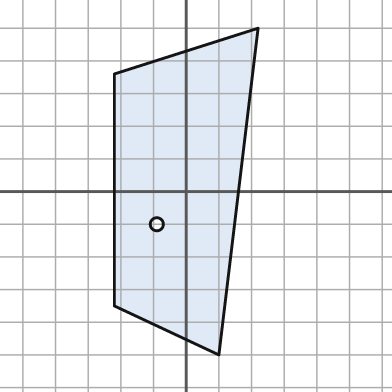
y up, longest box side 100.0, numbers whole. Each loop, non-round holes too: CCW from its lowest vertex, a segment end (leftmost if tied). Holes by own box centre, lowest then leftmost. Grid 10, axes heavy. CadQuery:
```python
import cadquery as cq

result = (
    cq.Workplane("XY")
    .moveTo(10.0, -50.0)
    .lineTo(22.0, 50.0)
    .lineTo(-22.0, 36.0)
    .lineTo(-22.0, -35.0)
    .close()
    .moveTo(-9.0, -10.0)
    .circle(2.0)
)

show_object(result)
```